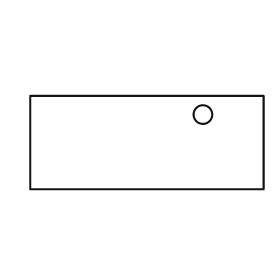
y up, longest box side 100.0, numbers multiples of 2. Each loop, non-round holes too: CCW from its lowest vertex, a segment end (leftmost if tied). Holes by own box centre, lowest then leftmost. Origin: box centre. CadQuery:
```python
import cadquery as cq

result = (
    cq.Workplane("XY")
    .moveTo(-50.0, -20.0)
    .lineTo(50.0, -20.0)
    .lineTo(50.0, 20.0)
    .lineTo(-50.0, 20.0)
    .close()
    .moveTo(24.0, 12.0)
    .circle(4.0)
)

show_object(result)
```